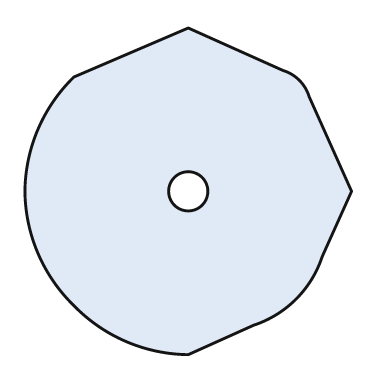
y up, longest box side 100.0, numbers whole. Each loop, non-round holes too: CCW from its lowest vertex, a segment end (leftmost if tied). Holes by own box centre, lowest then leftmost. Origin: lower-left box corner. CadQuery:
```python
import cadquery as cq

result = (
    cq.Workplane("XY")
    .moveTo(50.0, 0.0)
    .lineTo(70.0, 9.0)
    .threePointArc((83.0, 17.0), (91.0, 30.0))
    .lineTo(100.0, 50.0)
    .lineTo(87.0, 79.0)
    .threePointArc((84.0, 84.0), (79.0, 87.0))
    .lineTo(50.0, 100.0)
    .lineTo(15.0, 85.0)
    .threePointArc((4.0, 69.0), (0.0, 50.0))
    .threePointArc((4.0, 31.0), (15.0, 15.0))
    .threePointArc((31.0, 4.0), (50.0, 0.0))
    .close()
    .moveTo(50.0, 50.0)
    .circle(6.0)
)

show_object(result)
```